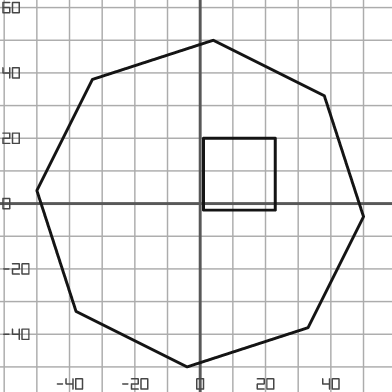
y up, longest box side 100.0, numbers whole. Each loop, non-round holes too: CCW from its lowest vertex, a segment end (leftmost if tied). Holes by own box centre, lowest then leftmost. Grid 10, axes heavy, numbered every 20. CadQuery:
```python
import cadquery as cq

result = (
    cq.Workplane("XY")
    .moveTo(-4.0, -50.0)
    .lineTo(33.0, -38.0)
    .lineTo(50.0, -4.0)
    .lineTo(38.0, 33.0)
    .lineTo(4.0, 50.0)
    .lineTo(-33.0, 38.0)
    .lineTo(-50.0, 4.0)
    .lineTo(-38.0, -33.0)
    .close()
    .moveTo(1.0, -2.0)
    .lineTo(23.0, -2.0)
    .lineTo(23.0, 20.0)
    .lineTo(1.0, 20.0)
    .close()
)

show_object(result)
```